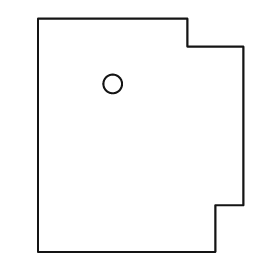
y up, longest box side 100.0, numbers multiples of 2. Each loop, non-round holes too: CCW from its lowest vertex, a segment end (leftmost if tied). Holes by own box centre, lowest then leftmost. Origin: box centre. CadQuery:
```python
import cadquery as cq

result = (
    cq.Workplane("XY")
    .moveTo(-44.0, -50.0)
    .lineTo(32.0, -50.0)
    .lineTo(32.0, -30.0)
    .lineTo(44.0, -30.0)
    .lineTo(44.0, 38.0)
    .lineTo(20.0, 38.0)
    .lineTo(20.0, 50.0)
    .lineTo(-44.0, 50.0)
    .close()
    .moveTo(-12.0, 22.0)
    .circle(4.0)
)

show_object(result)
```